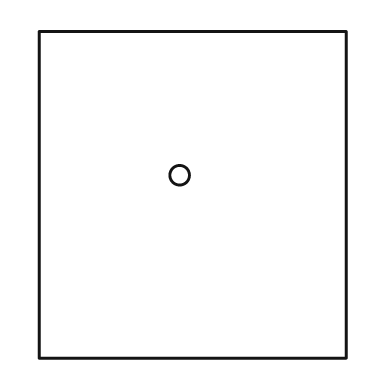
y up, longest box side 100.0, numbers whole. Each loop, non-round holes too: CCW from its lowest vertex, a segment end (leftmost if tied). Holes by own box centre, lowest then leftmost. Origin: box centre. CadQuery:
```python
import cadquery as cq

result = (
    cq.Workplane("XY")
    .moveTo(-47.0, -50.0)
    .lineTo(47.0, -50.0)
    .lineTo(47.0, 50.0)
    .lineTo(-47.0, 50.0)
    .close()
    .moveTo(-4.0, 6.0)
    .circle(3.0)
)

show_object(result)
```